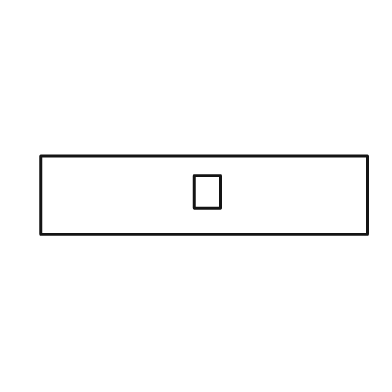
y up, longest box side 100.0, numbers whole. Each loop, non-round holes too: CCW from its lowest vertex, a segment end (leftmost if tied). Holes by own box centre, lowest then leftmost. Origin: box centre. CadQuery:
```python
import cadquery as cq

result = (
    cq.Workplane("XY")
    .moveTo(-50.0, -12.0)
    .lineTo(50.0, -12.0)
    .lineTo(50.0, 12.0)
    .lineTo(-50.0, 12.0)
    .close()
    .moveTo(-3.0, -4.0)
    .lineTo(5.0, -4.0)
    .lineTo(5.0, 6.0)
    .lineTo(-3.0, 6.0)
    .close()
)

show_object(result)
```